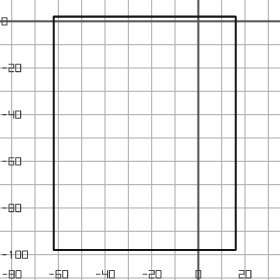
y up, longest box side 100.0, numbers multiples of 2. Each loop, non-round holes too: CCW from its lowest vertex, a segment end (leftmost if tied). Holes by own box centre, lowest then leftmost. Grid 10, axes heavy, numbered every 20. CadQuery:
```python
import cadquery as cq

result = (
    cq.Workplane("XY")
    .moveTo(-62.0, -98.0)
    .lineTo(16.0, -98.0)
    .lineTo(16.0, 2.0)
    .lineTo(-62.0, 2.0)
    .close()
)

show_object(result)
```